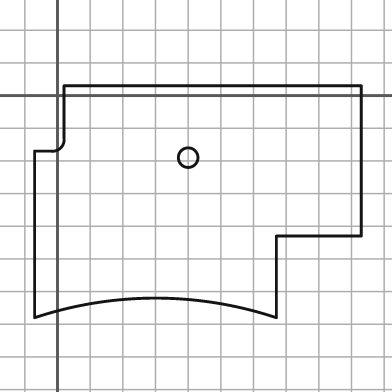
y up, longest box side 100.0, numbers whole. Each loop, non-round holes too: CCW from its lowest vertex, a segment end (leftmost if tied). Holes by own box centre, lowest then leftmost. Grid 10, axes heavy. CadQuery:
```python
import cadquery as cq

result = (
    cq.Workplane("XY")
    .moveTo(-7.0, -68.0)
    .threePointArc((30.0, -62.0), (67.0, -68.0))
    .lineTo(67.0, -43.0)
    .lineTo(93.0, -43.0)
    .lineTo(93.0, 3.0)
    .lineTo(2.0, 3.0)
    .lineTo(2.0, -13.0)
    .threePointArc((1.0, -16.0), (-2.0, -17.0))
    .lineTo(-7.0, -17.0)
    .close()
    .moveTo(40.0, -19.0)
    .circle(3.0)
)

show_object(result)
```